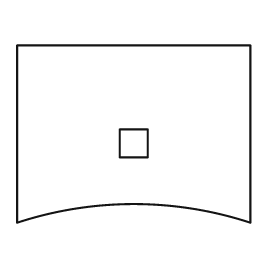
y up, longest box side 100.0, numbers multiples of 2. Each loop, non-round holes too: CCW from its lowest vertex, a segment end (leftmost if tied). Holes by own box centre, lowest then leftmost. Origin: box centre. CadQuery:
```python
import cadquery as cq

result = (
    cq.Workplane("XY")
    .moveTo(-50.0, -38.0)
    .threePointArc((0.0, -30.0), (50.0, -38.0))
    .lineTo(50.0, 38.0)
    .lineTo(-50.0, 38.0)
    .close()
    .moveTo(-6.0, -10.0)
    .lineTo(6.0, -10.0)
    .lineTo(6.0, 2.0)
    .lineTo(-6.0, 2.0)
    .close()
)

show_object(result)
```